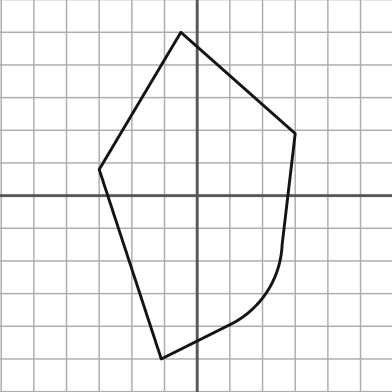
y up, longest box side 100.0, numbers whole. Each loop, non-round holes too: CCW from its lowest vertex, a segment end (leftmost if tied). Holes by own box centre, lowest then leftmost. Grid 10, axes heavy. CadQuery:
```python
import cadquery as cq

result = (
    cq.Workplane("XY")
    .moveTo(-11.0, -50.0)
    .lineTo(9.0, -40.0)
    .threePointArc((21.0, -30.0), (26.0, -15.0))
    .lineTo(30.0, 19.0)
    .lineTo(-5.0, 50.0)
    .lineTo(-30.0, 8.0)
    .close()
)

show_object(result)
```